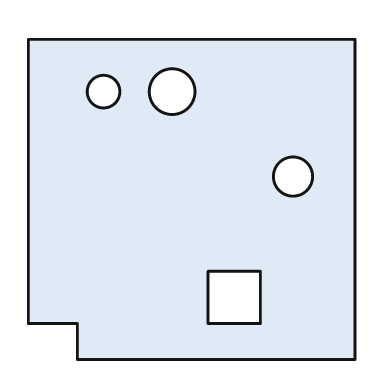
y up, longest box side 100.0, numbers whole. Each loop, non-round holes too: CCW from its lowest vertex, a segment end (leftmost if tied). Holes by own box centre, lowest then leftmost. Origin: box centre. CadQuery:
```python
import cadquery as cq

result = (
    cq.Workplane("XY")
    .moveTo(-35.0, -49.0)
    .lineTo(50.0, -49.0)
    .lineTo(50.0, 49.0)
    .lineTo(-50.0, 49.0)
    .lineTo(-50.0, -38.0)
    .lineTo(-35.0, -38.0)
    .close()
    .moveTo(5.0, -38.0)
    .lineTo(21.0, -38.0)
    .lineTo(21.0, -22.0)
    .lineTo(5.0, -22.0)
    .close()
    .moveTo(31.0, 7.0)
    .circle(6.0)
    .moveTo(-27.0, 33.0)
    .circle(5.0)
    .moveTo(-6.0, 33.0)
    .circle(7.0)
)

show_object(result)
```